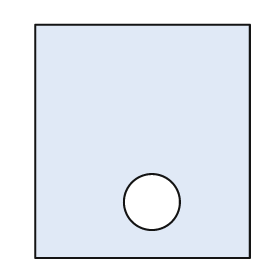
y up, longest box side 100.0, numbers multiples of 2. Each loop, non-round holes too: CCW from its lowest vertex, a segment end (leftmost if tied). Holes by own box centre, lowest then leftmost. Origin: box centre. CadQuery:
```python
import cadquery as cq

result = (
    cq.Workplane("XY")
    .moveTo(-46.0, -50.0)
    .lineTo(46.0, -50.0)
    .lineTo(46.0, 50.0)
    .lineTo(-46.0, 50.0)
    .close()
    .moveTo(4.0, -26.0)
    .circle(12.0)
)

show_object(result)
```